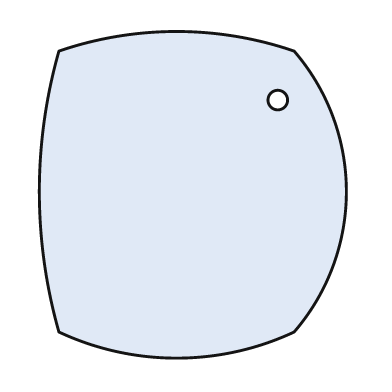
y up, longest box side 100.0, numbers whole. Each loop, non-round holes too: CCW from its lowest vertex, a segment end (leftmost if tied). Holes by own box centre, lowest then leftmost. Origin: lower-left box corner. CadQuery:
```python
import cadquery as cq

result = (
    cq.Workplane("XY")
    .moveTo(6.0, 8.0)
    .threePointArc((42.0, 0.0), (78.0, 8.0))
    .threePointArc((94.0, 51.0), (78.0, 94.0))
    .threePointArc((42.0, 100.0), (6.0, 94.0))
    .threePointArc((0.0, 51.0), (6.0, 8.0))
    .close()
    .moveTo(73.0, 79.0)
    .circle(3.0)
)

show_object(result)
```